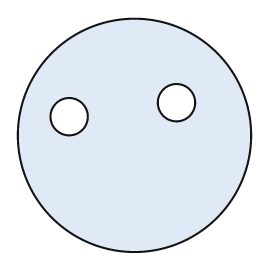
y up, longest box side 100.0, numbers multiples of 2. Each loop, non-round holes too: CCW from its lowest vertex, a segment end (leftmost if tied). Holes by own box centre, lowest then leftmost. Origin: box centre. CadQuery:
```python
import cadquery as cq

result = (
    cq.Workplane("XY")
    .moveTo(0.0, 0.0)
    .circle(50.0)
    .moveTo(-28.0, 8.0)
    .circle(8.0)
    .moveTo(18.0, 14.0)
    .circle(8.0)
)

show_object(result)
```